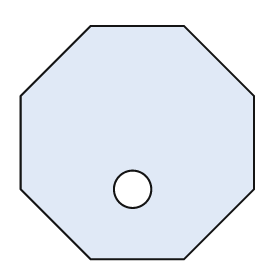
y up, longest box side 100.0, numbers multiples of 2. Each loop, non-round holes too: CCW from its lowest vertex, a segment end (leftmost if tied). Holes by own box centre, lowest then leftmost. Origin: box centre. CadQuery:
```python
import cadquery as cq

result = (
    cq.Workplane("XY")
    .moveTo(-20.0, -50.0)
    .lineTo(20.0, -50.0)
    .lineTo(50.0, -20.0)
    .lineTo(50.0, 20.0)
    .lineTo(20.0, 50.0)
    .lineTo(-20.0, 50.0)
    .lineTo(-50.0, 20.0)
    .lineTo(-50.0, -20.0)
    .close()
    .moveTo(-2.0, -20.0)
    .circle(8.0)
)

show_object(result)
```